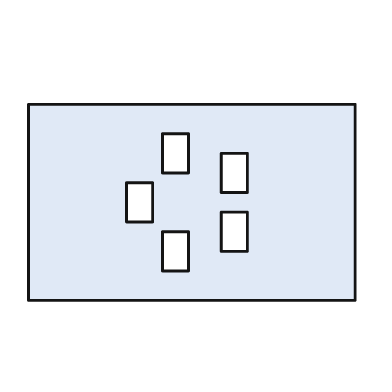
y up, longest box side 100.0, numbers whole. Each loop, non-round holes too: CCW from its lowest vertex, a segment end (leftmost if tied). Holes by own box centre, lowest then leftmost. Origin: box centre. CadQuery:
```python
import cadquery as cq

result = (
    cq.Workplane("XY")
    .moveTo(-50.0, -30.0)
    .lineTo(50.0, -30.0)
    .lineTo(50.0, 30.0)
    .lineTo(-50.0, 30.0)
    .close()
    .moveTo(-9.0, -21.0)
    .lineTo(-1.0, -21.0)
    .lineTo(-1.0, -9.0)
    .lineTo(-9.0, -9.0)
    .close()
    .moveTo(9.0, -15.0)
    .lineTo(17.0, -15.0)
    .lineTo(17.0, -3.0)
    .lineTo(9.0, -3.0)
    .close()
    .moveTo(-20.0, -6.0)
    .lineTo(-12.0, -6.0)
    .lineTo(-12.0, 6.0)
    .lineTo(-20.0, 6.0)
    .close()
    .moveTo(9.0, 3.0)
    .lineTo(17.0, 3.0)
    .lineTo(17.0, 15.0)
    .lineTo(9.0, 15.0)
    .close()
    .moveTo(-9.0, 9.0)
    .lineTo(-1.0, 9.0)
    .lineTo(-1.0, 21.0)
    .lineTo(-9.0, 21.0)
    .close()
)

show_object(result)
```